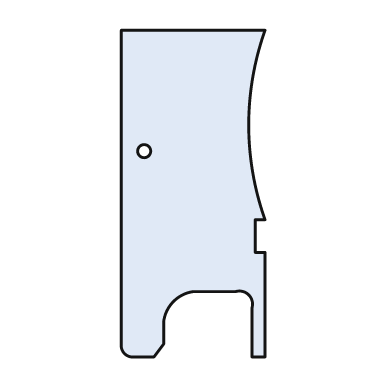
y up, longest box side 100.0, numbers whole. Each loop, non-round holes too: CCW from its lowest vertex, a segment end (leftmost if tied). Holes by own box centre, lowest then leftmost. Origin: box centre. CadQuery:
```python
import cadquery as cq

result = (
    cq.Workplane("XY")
    .moveTo(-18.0, -50.0)
    .lineTo(-12.0, -50.0)
    .lineTo(-9.0, -46.0)
    .lineTo(-9.0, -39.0)
    .threePointArc((-6.0, -33.0), (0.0, -30.0))
    .lineTo(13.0, -30.0)
    .threePointArc((17.0, -31.0), (18.0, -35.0))
    .lineTo(18.0, -50.0)
    .lineTo(22.0, -50.0)
    .lineTo(22.0, -18.0)
    .lineTo(19.0, -18.0)
    .lineTo(19.0, -8.0)
    .lineTo(22.0, -8.0)
    .threePointArc((17.0, 21.0), (22.0, 50.0))
    .lineTo(-22.0, 50.0)
    .lineTo(-22.0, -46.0)
    .threePointArc((-21.0, -49.0), (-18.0, -50.0))
    .close()
    .moveTo(-15.0, 13.0)
    .circle(2.0)
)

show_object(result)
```